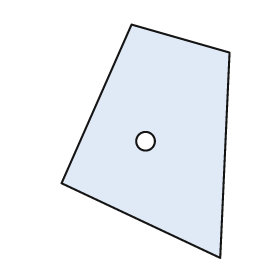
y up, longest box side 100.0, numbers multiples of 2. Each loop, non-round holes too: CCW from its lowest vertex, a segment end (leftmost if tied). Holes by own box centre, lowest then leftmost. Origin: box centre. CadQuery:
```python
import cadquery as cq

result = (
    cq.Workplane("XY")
    .moveTo(32.0, -50.0)
    .lineTo(36.0, 38.0)
    .lineTo(-6.0, 50.0)
    .lineTo(-36.0, -18.0)
    .close()
    .moveTo(0.0, 0.0)
    .circle(4.0)
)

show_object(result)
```